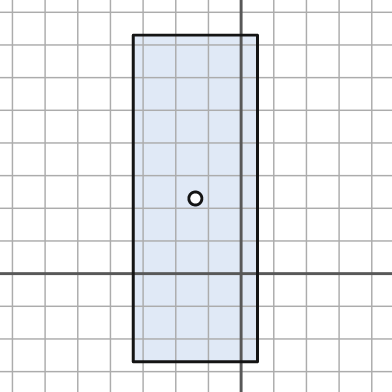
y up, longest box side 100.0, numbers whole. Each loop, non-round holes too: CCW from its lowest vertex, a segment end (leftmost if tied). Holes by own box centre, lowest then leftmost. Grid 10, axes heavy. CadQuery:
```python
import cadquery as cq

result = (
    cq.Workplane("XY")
    .moveTo(-33.0, -27.0)
    .lineTo(5.0, -27.0)
    .lineTo(5.0, 73.0)
    .lineTo(-33.0, 73.0)
    .close()
    .moveTo(-14.0, 23.0)
    .circle(2.0)
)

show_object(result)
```